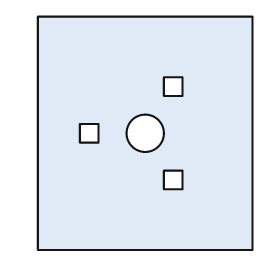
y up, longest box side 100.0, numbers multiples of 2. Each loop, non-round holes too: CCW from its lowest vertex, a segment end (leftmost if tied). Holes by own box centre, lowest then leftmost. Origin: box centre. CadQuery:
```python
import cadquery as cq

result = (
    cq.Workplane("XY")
    .moveTo(-46.0, -50.0)
    .lineTo(46.0, -50.0)
    .lineTo(46.0, 50.0)
    .lineTo(-46.0, 50.0)
    .close()
    .moveTo(8.0, -24.0)
    .lineTo(16.0, -24.0)
    .lineTo(16.0, -16.0)
    .lineTo(8.0, -16.0)
    .close()
    .moveTo(-28.0, -4.0)
    .lineTo(-20.0, -4.0)
    .lineTo(-20.0, 4.0)
    .lineTo(-28.0, 4.0)
    .close()
    .moveTo(0.0, 0.0)
    .circle(8.0)
    .moveTo(8.0, 16.0)
    .lineTo(16.0, 16.0)
    .lineTo(16.0, 24.0)
    .lineTo(8.0, 24.0)
    .close()
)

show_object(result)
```